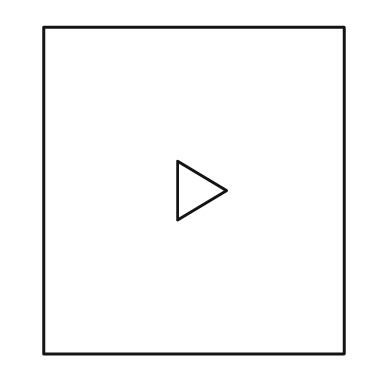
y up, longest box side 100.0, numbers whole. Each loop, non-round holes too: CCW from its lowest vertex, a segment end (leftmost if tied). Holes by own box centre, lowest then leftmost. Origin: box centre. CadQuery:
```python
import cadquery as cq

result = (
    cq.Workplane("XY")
    .moveTo(-46.0, -50.0)
    .lineTo(46.0, -50.0)
    .lineTo(46.0, 50.0)
    .lineTo(-46.0, 50.0)
    .close()
    .moveTo(-5.0, -9.0)
    .lineTo(10.0, 0.0)
    .lineTo(-5.0, 9.0)
    .close()
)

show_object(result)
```